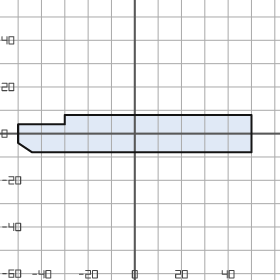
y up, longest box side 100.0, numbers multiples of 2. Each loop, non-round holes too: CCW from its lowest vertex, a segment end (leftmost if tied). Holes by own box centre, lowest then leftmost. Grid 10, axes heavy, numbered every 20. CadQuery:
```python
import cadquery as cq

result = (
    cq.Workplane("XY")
    .moveTo(-44.0, -8.0)
    .lineTo(50.0, -8.0)
    .lineTo(50.0, 8.0)
    .lineTo(-30.0, 8.0)
    .lineTo(-30.0, 4.0)
    .lineTo(-50.0, 4.0)
    .lineTo(-50.0, -4.0)
    .close()
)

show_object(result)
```